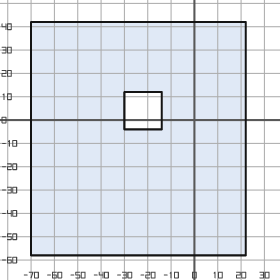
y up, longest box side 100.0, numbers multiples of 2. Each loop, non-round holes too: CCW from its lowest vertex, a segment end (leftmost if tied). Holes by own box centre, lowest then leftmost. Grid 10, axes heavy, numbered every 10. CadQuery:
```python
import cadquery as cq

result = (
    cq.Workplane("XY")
    .moveTo(-70.0, -58.0)
    .lineTo(22.0, -58.0)
    .lineTo(22.0, 42.0)
    .lineTo(-70.0, 42.0)
    .close()
    .moveTo(-30.0, -4.0)
    .lineTo(-14.0, -4.0)
    .lineTo(-14.0, 12.0)
    .lineTo(-30.0, 12.0)
    .close()
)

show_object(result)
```